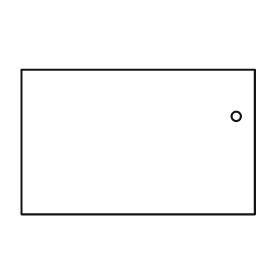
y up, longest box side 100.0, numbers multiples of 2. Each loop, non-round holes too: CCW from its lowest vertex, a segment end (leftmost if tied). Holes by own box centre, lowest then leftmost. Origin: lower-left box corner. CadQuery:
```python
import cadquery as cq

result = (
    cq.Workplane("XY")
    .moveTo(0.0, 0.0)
    .lineTo(100.0, 0.0)
    .lineTo(100.0, 62.0)
    .lineTo(0.0, 62.0)
    .close()
    .moveTo(92.0, 42.0)
    .circle(2.0)
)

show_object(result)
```